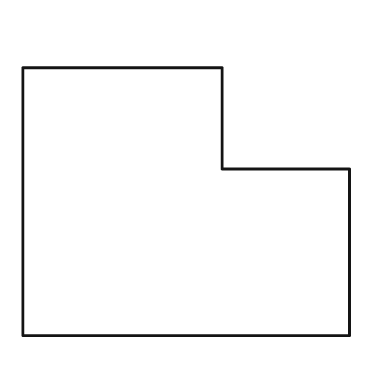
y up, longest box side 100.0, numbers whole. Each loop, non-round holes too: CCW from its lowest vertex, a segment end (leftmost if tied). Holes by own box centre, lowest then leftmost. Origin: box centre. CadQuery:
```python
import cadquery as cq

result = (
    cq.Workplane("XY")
    .moveTo(-50.0, -41.0)
    .lineTo(50.0, -41.0)
    .lineTo(50.0, 10.0)
    .lineTo(11.0, 10.0)
    .lineTo(11.0, 41.0)
    .lineTo(-50.0, 41.0)
    .close()
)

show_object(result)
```